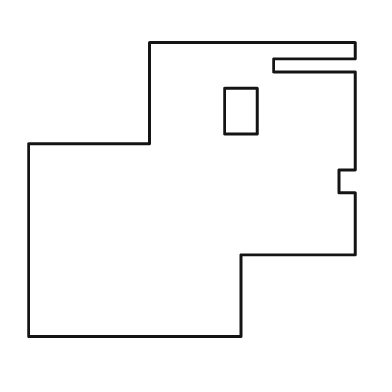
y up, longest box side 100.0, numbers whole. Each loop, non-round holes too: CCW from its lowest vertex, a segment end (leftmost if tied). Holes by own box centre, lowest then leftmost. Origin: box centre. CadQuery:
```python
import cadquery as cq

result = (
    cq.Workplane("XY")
    .moveTo(-50.0, -45.0)
    .lineTo(15.0, -45.0)
    .lineTo(15.0, -20.0)
    .lineTo(50.0, -20.0)
    .lineTo(50.0, -1.0)
    .lineTo(45.0, -1.0)
    .lineTo(45.0, 6.0)
    .lineTo(50.0, 6.0)
    .lineTo(50.0, 36.0)
    .lineTo(25.0, 36.0)
    .lineTo(25.0, 40.0)
    .lineTo(50.0, 40.0)
    .lineTo(50.0, 45.0)
    .lineTo(-13.0, 45.0)
    .lineTo(-13.0, 14.0)
    .lineTo(-50.0, 14.0)
    .close()
    .moveTo(10.0, 17.0)
    .lineTo(20.0, 17.0)
    .lineTo(20.0, 31.0)
    .lineTo(10.0, 31.0)
    .close()
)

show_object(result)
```